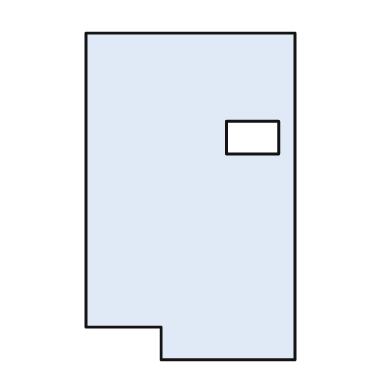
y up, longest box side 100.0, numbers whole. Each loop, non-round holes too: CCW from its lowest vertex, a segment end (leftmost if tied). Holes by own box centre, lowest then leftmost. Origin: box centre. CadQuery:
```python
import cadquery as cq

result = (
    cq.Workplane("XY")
    .moveTo(-9.0, -50.0)
    .lineTo(32.0, -50.0)
    .lineTo(32.0, 50.0)
    .lineTo(-32.0, 50.0)
    .lineTo(-32.0, -40.0)
    .lineTo(-9.0, -40.0)
    .close()
    .moveTo(11.0, 13.0)
    .lineTo(27.0, 13.0)
    .lineTo(27.0, 23.0)
    .lineTo(11.0, 23.0)
    .close()
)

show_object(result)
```